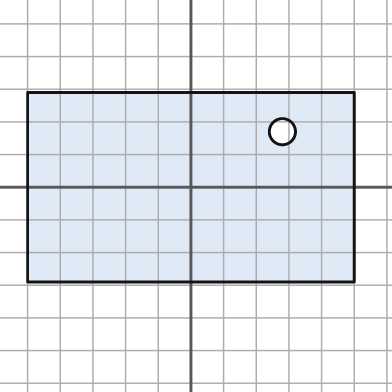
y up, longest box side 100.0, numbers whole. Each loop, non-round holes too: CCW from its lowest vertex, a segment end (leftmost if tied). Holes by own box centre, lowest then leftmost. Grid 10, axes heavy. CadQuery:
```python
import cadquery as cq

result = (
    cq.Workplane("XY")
    .moveTo(-50.0, -29.0)
    .lineTo(50.0, -29.0)
    .lineTo(50.0, 29.0)
    .lineTo(-50.0, 29.0)
    .close()
    .moveTo(28.0, 17.0)
    .circle(4.0)
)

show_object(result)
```